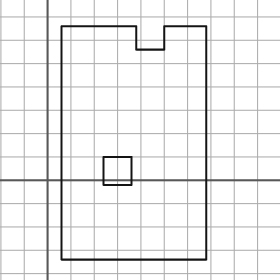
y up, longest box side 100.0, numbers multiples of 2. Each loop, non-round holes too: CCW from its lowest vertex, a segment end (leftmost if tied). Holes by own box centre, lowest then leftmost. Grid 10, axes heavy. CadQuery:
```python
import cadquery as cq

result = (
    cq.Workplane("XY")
    .moveTo(6.0, -34.0)
    .lineTo(68.0, -34.0)
    .lineTo(68.0, 66.0)
    .lineTo(50.0, 66.0)
    .lineTo(50.0, 56.0)
    .lineTo(38.0, 56.0)
    .lineTo(38.0, 66.0)
    .lineTo(6.0, 66.0)
    .close()
    .moveTo(24.0, -2.0)
    .lineTo(36.0, -2.0)
    .lineTo(36.0, 10.0)
    .lineTo(24.0, 10.0)
    .close()
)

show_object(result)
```